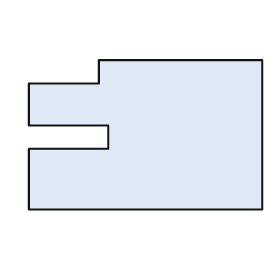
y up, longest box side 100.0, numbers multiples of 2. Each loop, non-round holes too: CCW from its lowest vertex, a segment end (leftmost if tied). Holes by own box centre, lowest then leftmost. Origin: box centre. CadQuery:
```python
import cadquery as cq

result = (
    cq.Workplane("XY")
    .moveTo(-50.0, -32.0)
    .lineTo(50.0, -32.0)
    .lineTo(50.0, 32.0)
    .lineTo(-20.0, 32.0)
    .lineTo(-20.0, 22.0)
    .lineTo(-50.0, 22.0)
    .lineTo(-50.0, 4.0)
    .lineTo(-16.0, 4.0)
    .lineTo(-16.0, -6.0)
    .lineTo(-50.0, -6.0)
    .close()
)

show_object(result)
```